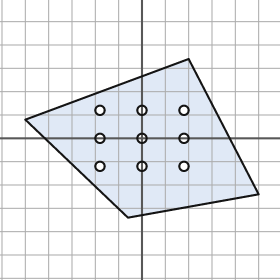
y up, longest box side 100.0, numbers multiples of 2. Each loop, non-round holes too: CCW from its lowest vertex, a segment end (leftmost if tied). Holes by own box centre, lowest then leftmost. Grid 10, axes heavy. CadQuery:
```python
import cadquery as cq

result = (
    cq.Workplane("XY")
    .moveTo(-6.0, -34.0)
    .lineTo(50.0, -24.0)
    .lineTo(20.0, 34.0)
    .lineTo(-50.0, 8.0)
    .close()
    .moveTo(-18.0, -12.0)
    .circle(2.0)
    .moveTo(0.0, -12.0)
    .circle(2.0)
    .moveTo(18.0, -12.0)
    .circle(2.0)
    .moveTo(-18.0, 0.0)
    .circle(2.0)
    .moveTo(0.0, 0.0)
    .circle(2.0)
    .moveTo(18.0, 0.0)
    .circle(2.0)
    .moveTo(-18.0, 12.0)
    .circle(2.0)
    .moveTo(0.0, 12.0)
    .circle(2.0)
    .moveTo(18.0, 12.0)
    .circle(2.0)
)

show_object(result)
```